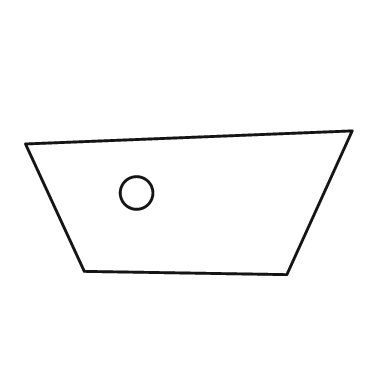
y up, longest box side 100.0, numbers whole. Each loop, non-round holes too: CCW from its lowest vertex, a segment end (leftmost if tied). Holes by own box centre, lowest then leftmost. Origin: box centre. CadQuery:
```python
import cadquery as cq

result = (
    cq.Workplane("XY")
    .moveTo(30.0, -22.0)
    .lineTo(50.0, 22.0)
    .lineTo(-50.0, 18.0)
    .lineTo(-32.0, -21.0)
    .close()
    .moveTo(-16.0, 3.0)
    .circle(5.0)
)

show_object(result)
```